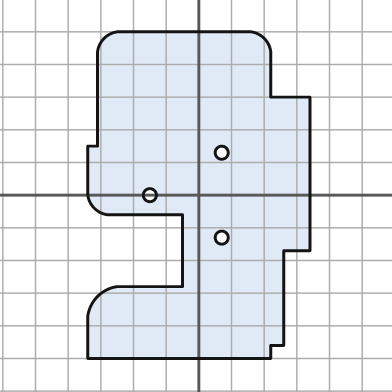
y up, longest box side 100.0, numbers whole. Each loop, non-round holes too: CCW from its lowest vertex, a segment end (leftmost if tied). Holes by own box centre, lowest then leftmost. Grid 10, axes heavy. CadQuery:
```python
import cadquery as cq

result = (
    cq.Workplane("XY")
    .moveTo(-34.0, -50.0)
    .lineTo(22.0, -50.0)
    .lineTo(22.0, -46.0)
    .lineTo(26.0, -46.0)
    .lineTo(26.0, -17.0)
    .lineTo(34.0, -17.0)
    .lineTo(34.0, 30.0)
    .lineTo(22.0, 30.0)
    .lineTo(22.0, 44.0)
    .threePointArc((20.0, 48.0), (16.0, 50.0))
    .lineTo(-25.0, 50.0)
    .threePointArc((-29.0, 48.0), (-31.0, 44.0))
    .lineTo(-31.0, 15.0)
    .lineTo(-34.0, 15.0)
    .lineTo(-34.0, 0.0)
    .threePointArc((-32.0, -4.0), (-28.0, -6.0))
    .lineTo(-5.0, -6.0)
    .lineTo(-5.0, -28.0)
    .lineTo(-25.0, -28.0)
    .threePointArc((-31.0, -31.0), (-34.0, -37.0))
    .close()
    .moveTo(7.0, -13.0)
    .circle(2.0)
    .moveTo(-15.0, 0.0)
    .circle(2.0)
    .moveTo(7.0, 13.0)
    .circle(2.0)
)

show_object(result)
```